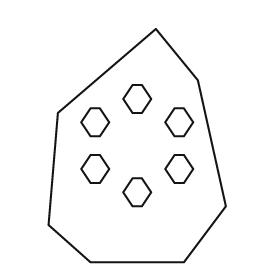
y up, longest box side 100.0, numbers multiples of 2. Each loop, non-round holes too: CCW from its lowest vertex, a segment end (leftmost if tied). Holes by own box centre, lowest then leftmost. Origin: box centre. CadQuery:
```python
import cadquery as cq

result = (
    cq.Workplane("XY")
    .moveTo(-20.0, -50.0)
    .lineTo(20.0, -50.0)
    .lineTo(38.0, -26.0)
    .lineTo(26.0, 28.0)
    .lineTo(8.0, 50.0)
    .lineTo(-34.0, 14.0)
    .lineTo(-38.0, -34.0)
    .close()
    .moveTo(-2.0, -26.0)
    .lineTo(2.0, -26.0)
    .lineTo(6.0, -20.0)
    .lineTo(2.0, -14.0)
    .lineTo(-2.0, -14.0)
    .lineTo(-6.0, -20.0)
    .close()
    .moveTo(-20.0, -16.0)
    .lineTo(-16.0, -16.0)
    .lineTo(-12.0, -10.0)
    .lineTo(-16.0, -4.0)
    .lineTo(-20.0, -4.0)
    .lineTo(-24.0, -10.0)
    .close()
    .moveTo(16.0, -16.0)
    .lineTo(20.0, -16.0)
    .lineTo(24.0, -10.0)
    .lineTo(20.0, -4.0)
    .lineTo(16.0, -4.0)
    .lineTo(12.0, -10.0)
    .close()
    .moveTo(-20.0, 4.0)
    .lineTo(-16.0, 4.0)
    .lineTo(-12.0, 10.0)
    .lineTo(-16.0, 16.0)
    .lineTo(-20.0, 16.0)
    .lineTo(-24.0, 10.0)
    .close()
    .moveTo(16.0, 4.0)
    .lineTo(20.0, 4.0)
    .lineTo(24.0, 10.0)
    .lineTo(20.0, 16.0)
    .lineTo(16.0, 16.0)
    .lineTo(12.0, 10.0)
    .close()
    .moveTo(-2.0, 14.0)
    .lineTo(2.0, 14.0)
    .lineTo(6.0, 20.0)
    .lineTo(2.0, 26.0)
    .lineTo(-2.0, 26.0)
    .lineTo(-6.0, 20.0)
    .close()
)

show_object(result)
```